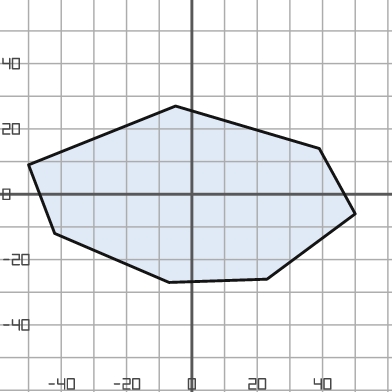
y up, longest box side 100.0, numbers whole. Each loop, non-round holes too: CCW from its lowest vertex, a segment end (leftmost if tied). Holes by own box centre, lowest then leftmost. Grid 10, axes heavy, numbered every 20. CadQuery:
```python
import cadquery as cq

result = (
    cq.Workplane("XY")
    .moveTo(-7.0, -27.0)
    .lineTo(23.0, -26.0)
    .lineTo(50.0, -6.0)
    .lineTo(39.0, 14.0)
    .lineTo(-5.0, 27.0)
    .lineTo(-50.0, 9.0)
    .lineTo(-42.0, -12.0)
    .close()
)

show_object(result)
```